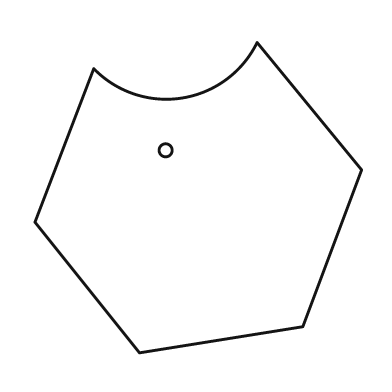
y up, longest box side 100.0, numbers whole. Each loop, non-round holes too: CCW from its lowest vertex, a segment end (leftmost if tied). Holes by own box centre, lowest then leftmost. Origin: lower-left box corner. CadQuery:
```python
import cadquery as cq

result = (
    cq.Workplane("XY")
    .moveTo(32.0, 0.0)
    .lineTo(82.0, 8.0)
    .lineTo(100.0, 56.0)
    .lineTo(68.0, 95.0)
    .threePointArc((45.0, 78.0), (18.0, 87.0))
    .lineTo(0.0, 40.0)
    .close()
    .moveTo(40.0, 62.0)
    .circle(2.0)
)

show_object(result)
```